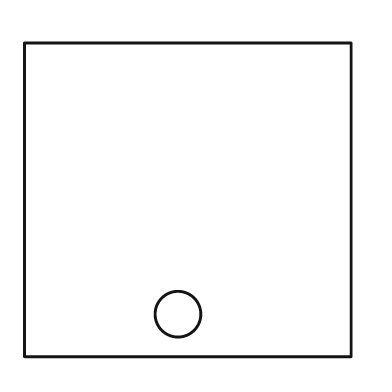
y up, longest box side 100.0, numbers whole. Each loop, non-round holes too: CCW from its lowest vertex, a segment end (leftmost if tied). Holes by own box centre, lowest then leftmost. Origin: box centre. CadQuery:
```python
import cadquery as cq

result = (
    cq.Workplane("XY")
    .moveTo(-50.0, -48.0)
    .lineTo(50.0, -48.0)
    .lineTo(50.0, 48.0)
    .lineTo(-50.0, 48.0)
    .close()
    .moveTo(-3.0, -35.0)
    .circle(7.0)
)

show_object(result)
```